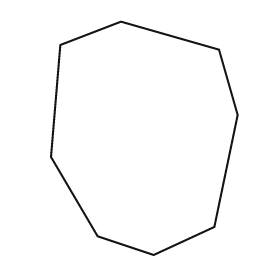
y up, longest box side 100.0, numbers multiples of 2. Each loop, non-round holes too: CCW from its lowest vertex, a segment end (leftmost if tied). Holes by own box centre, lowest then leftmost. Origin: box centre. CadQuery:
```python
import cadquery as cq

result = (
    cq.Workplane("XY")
    .moveTo(4.0, -50.0)
    .lineTo(30.0, -38.0)
    .lineTo(40.0, 10.0)
    .lineTo(32.0, 38.0)
    .lineTo(-10.0, 50.0)
    .lineTo(-36.0, 40.0)
    .lineTo(-40.0, -8.0)
    .lineTo(-20.0, -42.0)
    .close()
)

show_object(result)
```